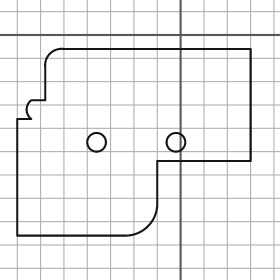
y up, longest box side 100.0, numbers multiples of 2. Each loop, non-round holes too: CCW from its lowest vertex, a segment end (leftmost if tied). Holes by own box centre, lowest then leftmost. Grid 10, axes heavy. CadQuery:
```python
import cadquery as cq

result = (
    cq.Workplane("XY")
    .moveTo(-70.0, -86.0)
    .lineTo(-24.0, -86.0)
    .threePointArc((-14.0, -82.0), (-10.0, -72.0))
    .lineTo(-10.0, -54.0)
    .lineTo(30.0, -54.0)
    .lineTo(30.0, -6.0)
    .lineTo(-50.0, -6.0)
    .threePointArc((-56.0, -8.0), (-58.0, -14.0))
    .lineTo(-58.0, -28.0)
    .lineTo(-64.0, -28.0)
    .threePointArc((-66.0, -32.0), (-64.0, -36.0))
    .lineTo(-70.0, -36.0)
    .close()
    .moveTo(-36.0, -46.0)
    .circle(4.0)
    .moveTo(-2.0, -46.0)
    .circle(4.0)
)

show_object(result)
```